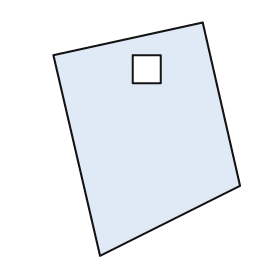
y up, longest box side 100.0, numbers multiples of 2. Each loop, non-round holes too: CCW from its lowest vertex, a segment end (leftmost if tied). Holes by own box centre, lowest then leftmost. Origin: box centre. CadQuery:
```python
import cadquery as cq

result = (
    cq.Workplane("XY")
    .moveTo(-20.0, -50.0)
    .lineTo(40.0, -20.0)
    .lineTo(24.0, 50.0)
    .lineTo(-40.0, 36.0)
    .close()
    .moveTo(-6.0, 24.0)
    .lineTo(6.0, 24.0)
    .lineTo(6.0, 36.0)
    .lineTo(-6.0, 36.0)
    .close()
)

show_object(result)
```